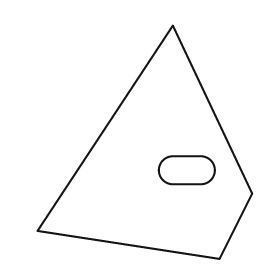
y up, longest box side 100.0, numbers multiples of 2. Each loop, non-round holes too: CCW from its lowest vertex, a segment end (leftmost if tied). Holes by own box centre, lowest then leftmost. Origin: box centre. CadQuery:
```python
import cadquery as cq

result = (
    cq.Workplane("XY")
    .moveTo(32.0, -50.0)
    .lineTo(46.0, -22.0)
    .lineTo(12.0, 50.0)
    .lineTo(-46.0, -38.0)
    .close()
    .moveTo(12.0, -18.0)
    .lineTo(24.0, -18.0)
    .threePointArc((30.0, -12.0), (24.0, -6.0))
    .lineTo(12.0, -6.0)
    .threePointArc((6.0, -12.0), (12.0, -18.0))
    .close()
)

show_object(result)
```